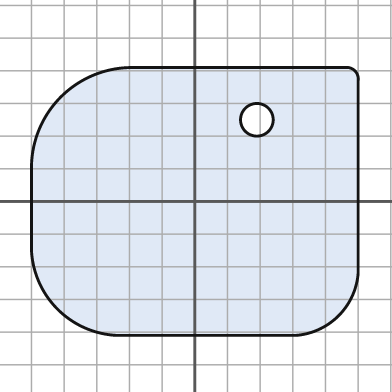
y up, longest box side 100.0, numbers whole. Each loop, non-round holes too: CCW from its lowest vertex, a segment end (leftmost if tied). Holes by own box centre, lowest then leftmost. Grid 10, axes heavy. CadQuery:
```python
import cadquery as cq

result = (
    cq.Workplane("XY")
    .moveTo(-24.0, -41.0)
    .lineTo(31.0, -41.0)
    .threePointArc((44.0, -35.0), (50.0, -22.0))
    .lineTo(50.0, 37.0)
    .threePointArc((49.0, 40.0), (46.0, 41.0))
    .lineTo(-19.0, 41.0)
    .threePointArc((-41.0, 32.0), (-50.0, 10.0))
    .lineTo(-50.0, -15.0)
    .threePointArc((-42.0, -33.0), (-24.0, -41.0))
    .close()
    .moveTo(19.0, 25.0)
    .circle(5.0)
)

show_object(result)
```